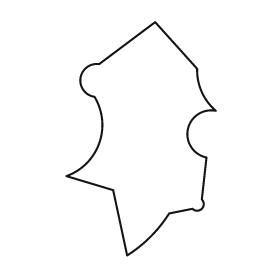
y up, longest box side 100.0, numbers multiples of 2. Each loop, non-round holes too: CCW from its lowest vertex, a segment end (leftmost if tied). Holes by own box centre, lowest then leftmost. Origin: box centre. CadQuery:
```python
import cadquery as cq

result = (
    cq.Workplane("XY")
    .moveTo(-6.0, -50.0)
    .threePointArc((4.0, -42.0), (12.0, -32.0))
    .lineTo(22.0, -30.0)
    .threePointArc((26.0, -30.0), (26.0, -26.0))
    .lineTo(28.0, -8.0)
    .threePointArc((20.0, 4.0), (32.0, 12.0))
    .threePointArc((26.0, 20.0), (24.0, 30.0))
    .lineTo(6.0, 50.0)
    .lineTo(-18.0, 32.0)
    .threePointArc((-26.0, 26.0), (-20.0, 18.0))
    .threePointArc((-18.0, -2.0), (-32.0, -16.0))
    .lineTo(-12.0, -22.0)
    .close()
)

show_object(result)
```